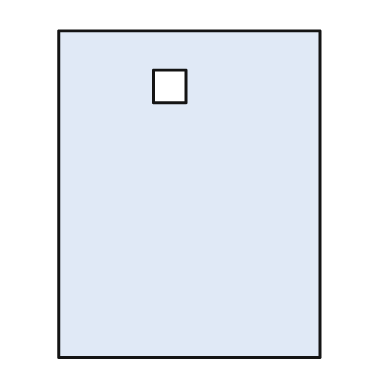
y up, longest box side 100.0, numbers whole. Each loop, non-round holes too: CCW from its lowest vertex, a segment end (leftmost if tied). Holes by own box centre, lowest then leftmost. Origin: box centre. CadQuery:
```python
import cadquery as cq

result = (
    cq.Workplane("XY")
    .moveTo(-40.0, -50.0)
    .lineTo(40.0, -50.0)
    .lineTo(40.0, 50.0)
    .lineTo(-40.0, 50.0)
    .close()
    .moveTo(-11.0, 28.0)
    .lineTo(-1.0, 28.0)
    .lineTo(-1.0, 38.0)
    .lineTo(-11.0, 38.0)
    .close()
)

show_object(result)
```